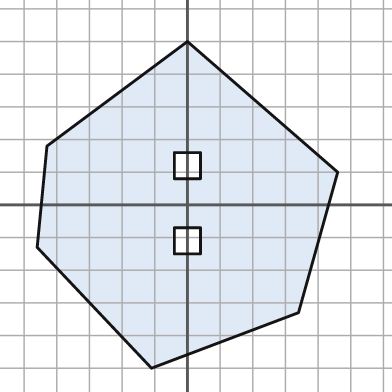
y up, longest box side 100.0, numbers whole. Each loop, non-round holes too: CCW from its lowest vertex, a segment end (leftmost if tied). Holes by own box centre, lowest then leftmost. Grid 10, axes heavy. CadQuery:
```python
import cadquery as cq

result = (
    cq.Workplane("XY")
    .moveTo(-11.0, -50.0)
    .lineTo(34.0, -33.0)
    .lineTo(46.0, 10.0)
    .lineTo(0.0, 50.0)
    .lineTo(-43.0, 18.0)
    .lineTo(-46.0, -13.0)
    .close()
    .moveTo(-4.0, -15.0)
    .lineTo(4.0, -15.0)
    .lineTo(4.0, -7.0)
    .lineTo(-4.0, -7.0)
    .close()
    .moveTo(-4.0, 8.0)
    .lineTo(4.0, 8.0)
    .lineTo(4.0, 16.0)
    .lineTo(-4.0, 16.0)
    .close()
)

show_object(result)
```